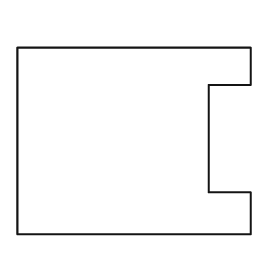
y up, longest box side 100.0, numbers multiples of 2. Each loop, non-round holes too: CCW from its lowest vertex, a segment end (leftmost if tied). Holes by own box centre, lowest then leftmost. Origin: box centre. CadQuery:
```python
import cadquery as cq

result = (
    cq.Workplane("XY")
    .moveTo(-50.0, -40.0)
    .lineTo(50.0, -40.0)
    .lineTo(50.0, -22.0)
    .lineTo(32.0, -22.0)
    .lineTo(32.0, 24.0)
    .lineTo(50.0, 24.0)
    .lineTo(50.0, 40.0)
    .lineTo(-50.0, 40.0)
    .close()
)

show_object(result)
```